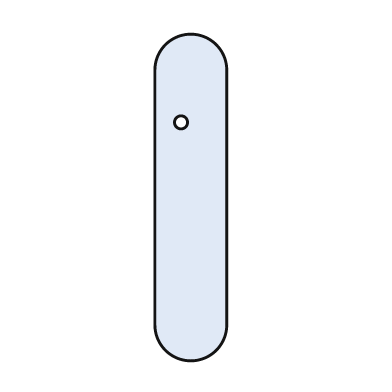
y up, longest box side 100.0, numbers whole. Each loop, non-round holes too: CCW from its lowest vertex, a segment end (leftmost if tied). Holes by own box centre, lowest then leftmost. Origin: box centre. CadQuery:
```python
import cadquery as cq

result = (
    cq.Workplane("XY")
    .moveTo(-11.0, -39.0)
    .threePointArc((0.0, -50.0), (11.0, -39.0))
    .lineTo(11.0, 39.0)
    .threePointArc((0.0, 50.0), (-11.0, 39.0))
    .close()
    .moveTo(-3.0, 23.0)
    .circle(2.0)
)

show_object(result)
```